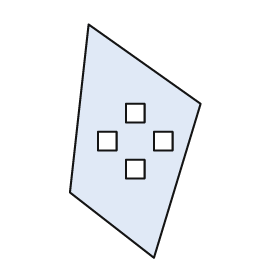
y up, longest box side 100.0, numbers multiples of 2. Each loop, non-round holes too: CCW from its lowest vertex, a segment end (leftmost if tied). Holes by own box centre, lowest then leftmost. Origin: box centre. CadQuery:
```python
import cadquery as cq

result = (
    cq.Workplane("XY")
    .moveTo(8.0, -50.0)
    .lineTo(28.0, 16.0)
    .lineTo(-20.0, 50.0)
    .lineTo(-28.0, -22.0)
    .close()
    .moveTo(-4.0, -16.0)
    .lineTo(4.0, -16.0)
    .lineTo(4.0, -8.0)
    .lineTo(-4.0, -8.0)
    .close()
    .moveTo(-16.0, -4.0)
    .lineTo(-8.0, -4.0)
    .lineTo(-8.0, 4.0)
    .lineTo(-16.0, 4.0)
    .close()
    .moveTo(8.0, -4.0)
    .lineTo(16.0, -4.0)
    .lineTo(16.0, 4.0)
    .lineTo(8.0, 4.0)
    .close()
    .moveTo(-4.0, 8.0)
    .lineTo(4.0, 8.0)
    .lineTo(4.0, 16.0)
    .lineTo(-4.0, 16.0)
    .close()
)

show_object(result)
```